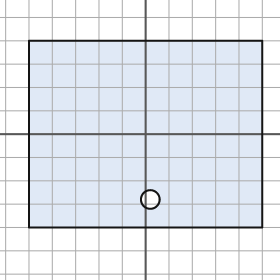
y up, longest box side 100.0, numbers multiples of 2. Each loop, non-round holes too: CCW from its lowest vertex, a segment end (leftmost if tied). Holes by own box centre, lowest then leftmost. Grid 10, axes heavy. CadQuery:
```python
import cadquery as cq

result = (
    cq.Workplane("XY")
    .moveTo(-50.0, -40.0)
    .lineTo(50.0, -40.0)
    .lineTo(50.0, 40.0)
    .lineTo(-50.0, 40.0)
    .close()
    .moveTo(2.0, -28.0)
    .circle(4.0)
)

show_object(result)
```